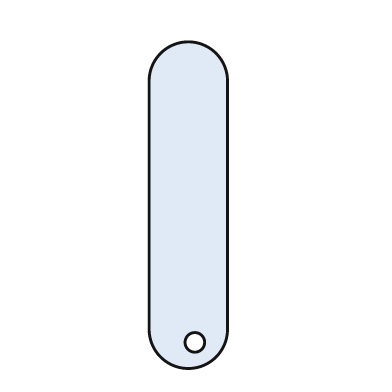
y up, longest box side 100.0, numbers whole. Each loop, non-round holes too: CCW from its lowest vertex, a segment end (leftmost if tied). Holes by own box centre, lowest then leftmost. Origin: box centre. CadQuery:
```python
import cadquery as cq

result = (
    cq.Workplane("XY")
    .moveTo(-12.0, -38.0)
    .threePointArc((0.0, -50.0), (12.0, -38.0))
    .lineTo(12.0, 38.0)
    .threePointArc((0.0, 50.0), (-12.0, 38.0))
    .close()
    .moveTo(2.0, -42.0)
    .circle(3.0)
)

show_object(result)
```